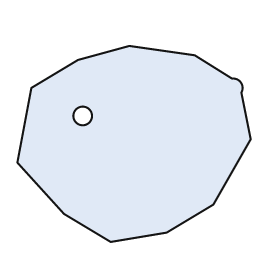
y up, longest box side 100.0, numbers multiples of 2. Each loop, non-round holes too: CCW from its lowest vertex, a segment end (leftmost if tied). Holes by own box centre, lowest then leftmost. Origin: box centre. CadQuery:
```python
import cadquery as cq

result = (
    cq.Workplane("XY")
    .moveTo(-10.0, -42.0)
    .lineTo(14.0, -38.0)
    .lineTo(34.0, -26.0)
    .lineTo(50.0, 2.0)
    .lineTo(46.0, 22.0)
    .threePointArc((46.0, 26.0), (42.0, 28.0))
    .lineTo(26.0, 38.0)
    .lineTo(-2.0, 42.0)
    .lineTo(-24.0, 36.0)
    .lineTo(-44.0, 24.0)
    .lineTo(-50.0, -8.0)
    .lineTo(-30.0, -30.0)
    .close()
    .moveTo(-22.0, 12.0)
    .circle(4.0)
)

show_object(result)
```